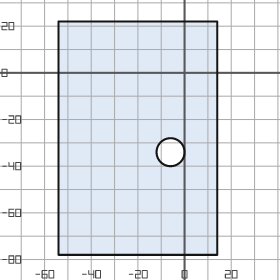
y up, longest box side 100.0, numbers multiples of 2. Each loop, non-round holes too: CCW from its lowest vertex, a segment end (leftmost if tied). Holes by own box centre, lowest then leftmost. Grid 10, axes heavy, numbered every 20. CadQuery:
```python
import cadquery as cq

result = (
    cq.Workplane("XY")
    .moveTo(-54.0, -78.0)
    .lineTo(14.0, -78.0)
    .lineTo(14.0, 22.0)
    .lineTo(-54.0, 22.0)
    .close()
    .moveTo(-6.0, -34.0)
    .circle(6.0)
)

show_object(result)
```